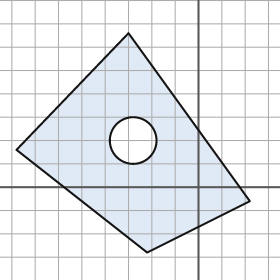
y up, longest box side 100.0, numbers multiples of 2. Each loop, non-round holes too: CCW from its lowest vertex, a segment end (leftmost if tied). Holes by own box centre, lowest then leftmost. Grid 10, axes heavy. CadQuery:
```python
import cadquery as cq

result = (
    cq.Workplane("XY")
    .moveTo(-22.0, -28.0)
    .lineTo(22.0, -6.0)
    .lineTo(-30.0, 66.0)
    .lineTo(-78.0, 16.0)
    .close()
    .moveTo(-28.0, 20.0)
    .circle(10.0)
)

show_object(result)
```